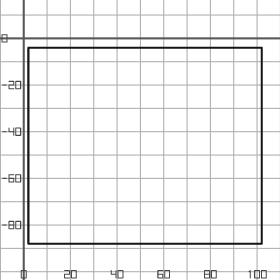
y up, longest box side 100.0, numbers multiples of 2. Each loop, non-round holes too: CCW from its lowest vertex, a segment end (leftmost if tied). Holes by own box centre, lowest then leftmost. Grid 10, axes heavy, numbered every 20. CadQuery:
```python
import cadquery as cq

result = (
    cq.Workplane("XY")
    .moveTo(2.0, -88.0)
    .lineTo(102.0, -88.0)
    .lineTo(102.0, -4.0)
    .lineTo(2.0, -4.0)
    .close()
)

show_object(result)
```